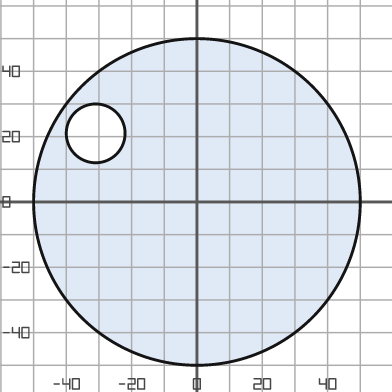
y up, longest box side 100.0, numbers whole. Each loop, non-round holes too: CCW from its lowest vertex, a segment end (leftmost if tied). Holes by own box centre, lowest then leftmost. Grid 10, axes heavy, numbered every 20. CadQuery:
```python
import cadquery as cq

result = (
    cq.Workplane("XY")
    .moveTo(0.0, 0.0)
    .circle(50.0)
    .moveTo(-31.0, 21.0)
    .circle(9.0)
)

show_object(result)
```